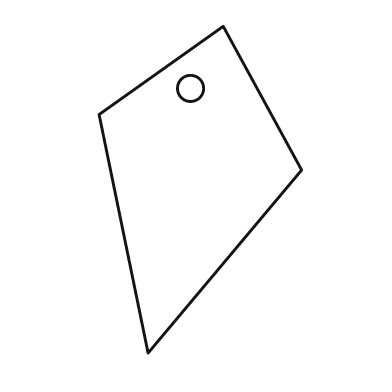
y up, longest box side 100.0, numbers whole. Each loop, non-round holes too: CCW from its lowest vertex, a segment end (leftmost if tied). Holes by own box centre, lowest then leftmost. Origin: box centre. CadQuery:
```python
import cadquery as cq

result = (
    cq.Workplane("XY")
    .moveTo(-16.0, -50.0)
    .lineTo(31.0, 6.0)
    .lineTo(7.0, 50.0)
    .lineTo(-31.0, 23.0)
    .close()
    .moveTo(-3.0, 31.0)
    .circle(4.0)
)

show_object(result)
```